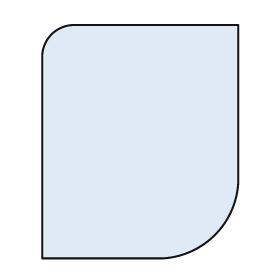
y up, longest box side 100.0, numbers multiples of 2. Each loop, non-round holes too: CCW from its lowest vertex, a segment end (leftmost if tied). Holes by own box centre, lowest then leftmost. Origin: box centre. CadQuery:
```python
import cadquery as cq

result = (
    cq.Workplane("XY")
    .moveTo(-42.0, -50.0)
    .lineTo(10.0, -50.0)
    .threePointArc((32.0, -40.0), (42.0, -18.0))
    .lineTo(42.0, 50.0)
    .lineTo(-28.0, 50.0)
    .threePointArc((-38.0, 46.0), (-42.0, 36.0))
    .close()
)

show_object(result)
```